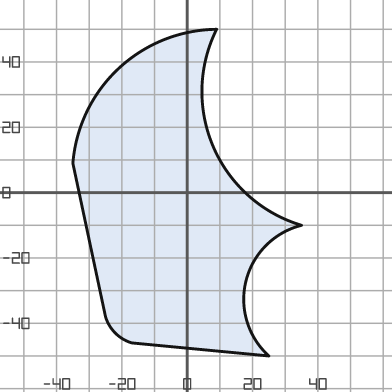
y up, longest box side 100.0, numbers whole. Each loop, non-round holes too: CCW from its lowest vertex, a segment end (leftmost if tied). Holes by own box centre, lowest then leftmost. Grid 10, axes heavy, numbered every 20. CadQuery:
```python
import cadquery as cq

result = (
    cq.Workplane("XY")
    .moveTo(25.0, -50.0)
    .threePointArc((18.0, -27.0), (35.0, -10.0))
    .threePointArc((8.0, 14.0), (9.0, 50.0))
    .threePointArc((-21.0, 38.0), (-35.0, 9.0))
    .lineTo(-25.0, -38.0)
    .threePointArc((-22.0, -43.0), (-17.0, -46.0))
    .close()
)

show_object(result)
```